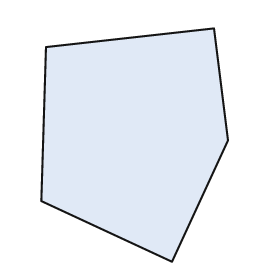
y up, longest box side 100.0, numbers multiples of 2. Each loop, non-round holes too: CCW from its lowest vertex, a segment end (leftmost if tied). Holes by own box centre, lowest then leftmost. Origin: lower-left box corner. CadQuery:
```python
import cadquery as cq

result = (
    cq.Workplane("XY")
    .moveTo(56.0, 0.0)
    .lineTo(80.0, 52.0)
    .lineTo(74.0, 100.0)
    .lineTo(2.0, 92.0)
    .lineTo(0.0, 26.0)
    .close()
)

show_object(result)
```